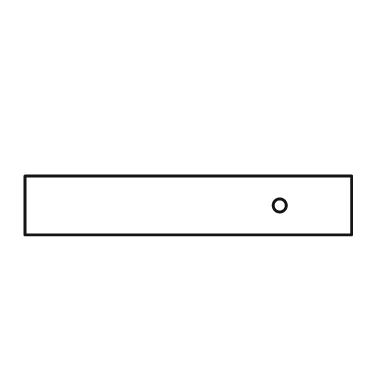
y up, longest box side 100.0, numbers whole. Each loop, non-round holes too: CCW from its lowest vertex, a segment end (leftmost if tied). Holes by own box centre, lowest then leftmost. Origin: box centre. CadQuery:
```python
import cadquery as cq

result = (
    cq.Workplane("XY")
    .moveTo(-50.0, -9.0)
    .lineTo(50.0, -9.0)
    .lineTo(50.0, 9.0)
    .lineTo(-50.0, 9.0)
    .close()
    .moveTo(28.0, 0.0)
    .circle(2.0)
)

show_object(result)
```